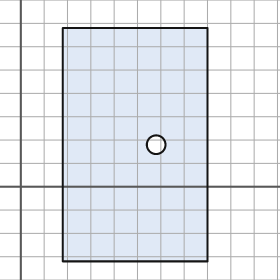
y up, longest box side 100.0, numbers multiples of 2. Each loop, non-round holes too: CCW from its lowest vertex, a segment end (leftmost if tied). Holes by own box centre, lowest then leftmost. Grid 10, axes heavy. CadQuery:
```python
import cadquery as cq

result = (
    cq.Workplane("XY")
    .moveTo(18.0, -32.0)
    .lineTo(80.0, -32.0)
    .lineTo(80.0, 68.0)
    .lineTo(18.0, 68.0)
    .close()
    .moveTo(58.0, 18.0)
    .circle(4.0)
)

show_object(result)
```